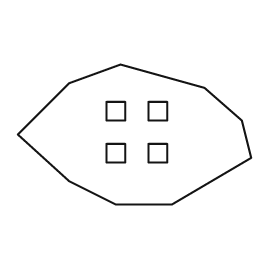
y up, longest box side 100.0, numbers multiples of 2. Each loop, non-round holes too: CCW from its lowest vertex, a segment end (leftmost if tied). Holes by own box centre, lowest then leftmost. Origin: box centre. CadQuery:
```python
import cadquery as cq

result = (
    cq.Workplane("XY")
    .moveTo(-8.0, -30.0)
    .lineTo(16.0, -30.0)
    .lineTo(50.0, -10.0)
    .lineTo(46.0, 6.0)
    .lineTo(30.0, 20.0)
    .lineTo(-6.0, 30.0)
    .lineTo(-28.0, 22.0)
    .lineTo(-50.0, 0.0)
    .lineTo(-28.0, -20.0)
    .close()
    .moveTo(-12.0, -12.0)
    .lineTo(-4.0, -12.0)
    .lineTo(-4.0, -4.0)
    .lineTo(-12.0, -4.0)
    .close()
    .moveTo(6.0, -12.0)
    .lineTo(14.0, -12.0)
    .lineTo(14.0, -4.0)
    .lineTo(6.0, -4.0)
    .close()
    .moveTo(-12.0, 6.0)
    .lineTo(-4.0, 6.0)
    .lineTo(-4.0, 14.0)
    .lineTo(-12.0, 14.0)
    .close()
    .moveTo(6.0, 6.0)
    .lineTo(14.0, 6.0)
    .lineTo(14.0, 14.0)
    .lineTo(6.0, 14.0)
    .close()
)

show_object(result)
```